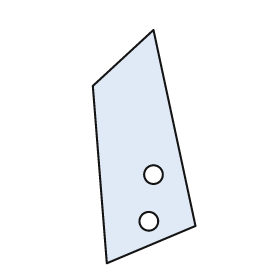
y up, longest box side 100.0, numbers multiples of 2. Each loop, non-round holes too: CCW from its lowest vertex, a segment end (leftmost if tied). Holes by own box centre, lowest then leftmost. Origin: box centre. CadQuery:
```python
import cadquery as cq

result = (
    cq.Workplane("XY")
    .moveTo(-16.0, -50.0)
    .lineTo(22.0, -34.0)
    .lineTo(4.0, 50.0)
    .lineTo(-22.0, 26.0)
    .close()
    .moveTo(2.0, -32.0)
    .circle(4.0)
    .moveTo(4.0, -12.0)
    .circle(4.0)
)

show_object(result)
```